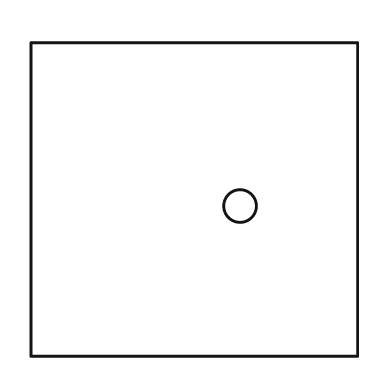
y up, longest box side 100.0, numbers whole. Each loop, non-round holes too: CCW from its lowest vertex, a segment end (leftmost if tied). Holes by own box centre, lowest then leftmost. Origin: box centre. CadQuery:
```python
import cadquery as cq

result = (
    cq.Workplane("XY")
    .moveTo(-50.0, -48.0)
    .lineTo(50.0, -48.0)
    .lineTo(50.0, 48.0)
    .lineTo(-50.0, 48.0)
    .close()
    .moveTo(14.0, -2.0)
    .circle(5.0)
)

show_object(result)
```